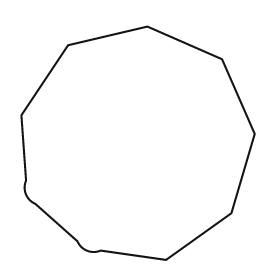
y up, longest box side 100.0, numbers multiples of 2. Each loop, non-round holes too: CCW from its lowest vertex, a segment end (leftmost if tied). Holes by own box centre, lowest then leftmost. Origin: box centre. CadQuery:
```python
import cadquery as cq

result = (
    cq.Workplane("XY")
    .moveTo(12.0, -50.0)
    .lineTo(40.0, -30.0)
    .lineTo(50.0, 4.0)
    .lineTo(36.0, 36.0)
    .lineTo(4.0, 50.0)
    .lineTo(-30.0, 42.0)
    .lineTo(-50.0, 12.0)
    .lineTo(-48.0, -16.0)
    .threePointArc((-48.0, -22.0), (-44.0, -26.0))
    .lineTo(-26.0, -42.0)
    .threePointArc((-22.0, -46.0), (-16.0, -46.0))
    .close()
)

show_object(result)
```